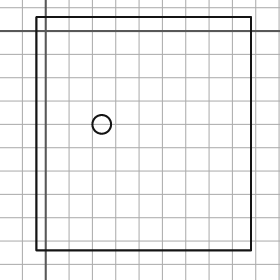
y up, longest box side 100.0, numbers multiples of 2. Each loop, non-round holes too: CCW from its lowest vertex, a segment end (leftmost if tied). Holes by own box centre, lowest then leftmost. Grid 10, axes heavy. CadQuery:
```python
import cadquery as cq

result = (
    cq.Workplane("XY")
    .moveTo(-4.0, -94.0)
    .lineTo(88.0, -94.0)
    .lineTo(88.0, 6.0)
    .lineTo(-4.0, 6.0)
    .close()
    .moveTo(24.0, -40.0)
    .circle(4.0)
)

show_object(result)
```